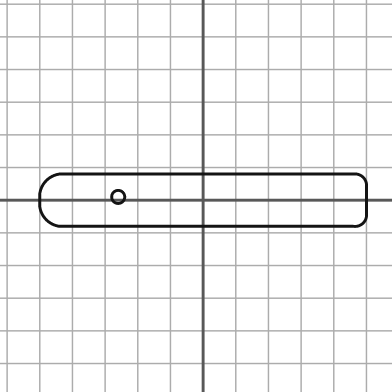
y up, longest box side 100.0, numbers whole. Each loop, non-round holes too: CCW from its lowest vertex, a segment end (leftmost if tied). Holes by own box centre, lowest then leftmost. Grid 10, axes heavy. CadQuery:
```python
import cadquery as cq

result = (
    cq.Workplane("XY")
    .moveTo(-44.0, -8.0)
    .lineTo(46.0, -8.0)
    .threePointArc((49.0, -7.0), (50.0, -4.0))
    .lineTo(50.0, 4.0)
    .threePointArc((49.0, 7.0), (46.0, 8.0))
    .lineTo(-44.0, 8.0)
    .threePointArc((-48.0, 6.0), (-50.0, 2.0))
    .lineTo(-50.0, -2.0)
    .threePointArc((-48.0, -6.0), (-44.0, -8.0))
    .close()
    .moveTo(-26.0, 1.0)
    .circle(2.0)
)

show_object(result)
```